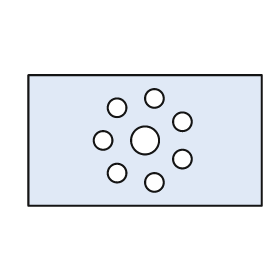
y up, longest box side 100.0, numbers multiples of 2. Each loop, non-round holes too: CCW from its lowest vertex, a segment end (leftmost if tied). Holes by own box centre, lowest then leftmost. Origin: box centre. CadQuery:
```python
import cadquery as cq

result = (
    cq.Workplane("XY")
    .moveTo(-50.0, -28.0)
    .lineTo(50.0, -28.0)
    .lineTo(50.0, 28.0)
    .lineTo(-50.0, 28.0)
    .close()
    .moveTo(4.0, -18.0)
    .circle(4.0)
    .moveTo(-12.0, -14.0)
    .circle(4.0)
    .moveTo(16.0, -8.0)
    .circle(4.0)
    .moveTo(-18.0, 0.0)
    .circle(4.0)
    .moveTo(0.0, 0.0)
    .circle(6.0)
    .moveTo(16.0, 8.0)
    .circle(4.0)
    .moveTo(-12.0, 14.0)
    .circle(4.0)
    .moveTo(4.0, 18.0)
    .circle(4.0)
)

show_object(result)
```